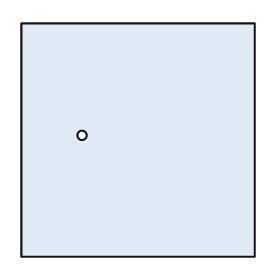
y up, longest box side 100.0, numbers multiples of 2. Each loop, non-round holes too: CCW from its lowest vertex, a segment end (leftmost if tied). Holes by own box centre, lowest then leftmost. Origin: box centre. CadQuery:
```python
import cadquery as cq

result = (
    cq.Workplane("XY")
    .moveTo(-50.0, -50.0)
    .lineTo(50.0, -50.0)
    .lineTo(50.0, 50.0)
    .lineTo(-50.0, 50.0)
    .close()
    .moveTo(-24.0, 2.0)
    .circle(2.0)
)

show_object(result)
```